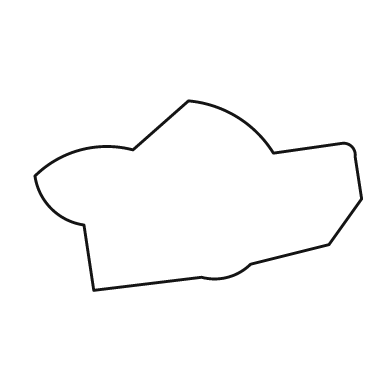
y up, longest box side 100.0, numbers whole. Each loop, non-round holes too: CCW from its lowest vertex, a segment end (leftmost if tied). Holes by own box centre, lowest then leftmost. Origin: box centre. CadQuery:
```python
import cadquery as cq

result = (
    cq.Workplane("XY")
    .moveTo(-32.0, -29.0)
    .lineTo(1.0, -25.0)
    .threePointArc((9.0, -25.0), (16.0, -21.0))
    .lineTo(40.0, -15.0)
    .lineTo(50.0, -1.0)
    .lineTo(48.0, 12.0)
    .threePointArc((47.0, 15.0), (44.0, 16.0))
    .lineTo(23.0, 13.0)
    .threePointArc((12.0, 24.0), (-3.0, 29.0))
    .lineTo(-20.0, 14.0)
    .threePointArc((-36.0, 14.0), (-50.0, 6.0))
    .threePointArc((-45.0, -4.0), (-35.0, -9.0))
    .close()
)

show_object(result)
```